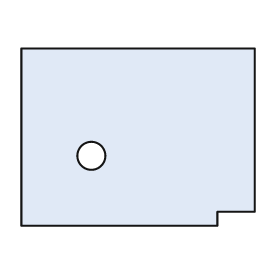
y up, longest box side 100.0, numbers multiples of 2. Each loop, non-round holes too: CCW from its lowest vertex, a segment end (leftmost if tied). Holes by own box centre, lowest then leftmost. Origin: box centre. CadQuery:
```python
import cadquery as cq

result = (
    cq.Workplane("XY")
    .moveTo(-50.0, -38.0)
    .lineTo(34.0, -38.0)
    .lineTo(34.0, -32.0)
    .lineTo(50.0, -32.0)
    .lineTo(50.0, 38.0)
    .lineTo(-50.0, 38.0)
    .close()
    .moveTo(-20.0, -8.0)
    .circle(6.0)
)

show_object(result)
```